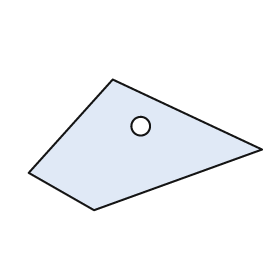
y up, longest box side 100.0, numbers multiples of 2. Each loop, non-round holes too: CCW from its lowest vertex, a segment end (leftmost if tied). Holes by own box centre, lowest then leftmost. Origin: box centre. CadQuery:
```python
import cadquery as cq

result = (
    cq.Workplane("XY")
    .moveTo(-22.0, -28.0)
    .lineTo(50.0, -2.0)
    .lineTo(-14.0, 28.0)
    .lineTo(-50.0, -12.0)
    .close()
    .moveTo(-2.0, 8.0)
    .circle(4.0)
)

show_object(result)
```